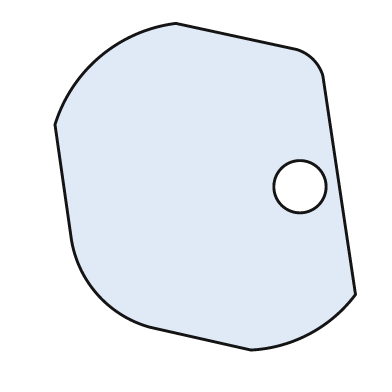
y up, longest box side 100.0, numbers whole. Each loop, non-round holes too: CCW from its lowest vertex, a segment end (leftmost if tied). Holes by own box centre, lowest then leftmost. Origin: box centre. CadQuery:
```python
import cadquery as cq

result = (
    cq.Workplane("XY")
    .moveTo(14.0, -50.0)
    .threePointArc((32.0, -45.0), (46.0, -33.0))
    .lineTo(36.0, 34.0)
    .threePointArc((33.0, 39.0), (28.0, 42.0))
    .lineTo(-9.0, 50.0)
    .threePointArc((-32.0, 40.0), (-46.0, 19.0))
    .lineTo(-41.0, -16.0)
    .threePointArc((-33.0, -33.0), (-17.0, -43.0))
    .close()
    .moveTo(29.0, 0.0)
    .circle(8.0)
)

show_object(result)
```